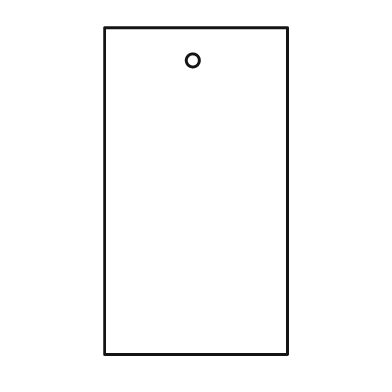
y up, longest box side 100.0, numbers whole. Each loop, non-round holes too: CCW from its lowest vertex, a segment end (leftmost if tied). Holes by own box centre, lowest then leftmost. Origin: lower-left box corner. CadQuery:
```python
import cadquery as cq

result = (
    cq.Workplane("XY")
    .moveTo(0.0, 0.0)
    .lineTo(56.0, 0.0)
    .lineTo(56.0, 100.0)
    .lineTo(0.0, 100.0)
    .close()
    .moveTo(27.0, 90.0)
    .circle(2.0)
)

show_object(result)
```